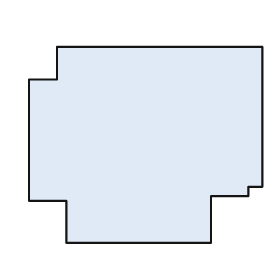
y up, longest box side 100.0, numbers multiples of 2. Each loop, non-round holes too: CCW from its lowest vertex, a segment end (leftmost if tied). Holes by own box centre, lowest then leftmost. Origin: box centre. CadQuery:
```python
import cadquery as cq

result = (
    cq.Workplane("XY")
    .moveTo(-34.0, -42.0)
    .lineTo(28.0, -42.0)
    .lineTo(28.0, -22.0)
    .lineTo(44.0, -22.0)
    .lineTo(44.0, -18.0)
    .lineTo(50.0, -18.0)
    .lineTo(50.0, 42.0)
    .lineTo(-38.0, 42.0)
    .lineTo(-38.0, 28.0)
    .lineTo(-50.0, 28.0)
    .lineTo(-50.0, -24.0)
    .lineTo(-34.0, -24.0)
    .close()
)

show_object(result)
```